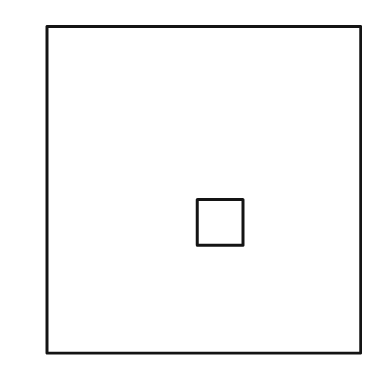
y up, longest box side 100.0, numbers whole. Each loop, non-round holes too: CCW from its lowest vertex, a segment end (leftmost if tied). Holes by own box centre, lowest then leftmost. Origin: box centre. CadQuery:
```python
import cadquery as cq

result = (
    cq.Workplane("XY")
    .moveTo(-48.0, -50.0)
    .lineTo(48.0, -50.0)
    .lineTo(48.0, 50.0)
    .lineTo(-48.0, 50.0)
    .close()
    .moveTo(-2.0, -17.0)
    .lineTo(12.0, -17.0)
    .lineTo(12.0, -3.0)
    .lineTo(-2.0, -3.0)
    .close()
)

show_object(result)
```